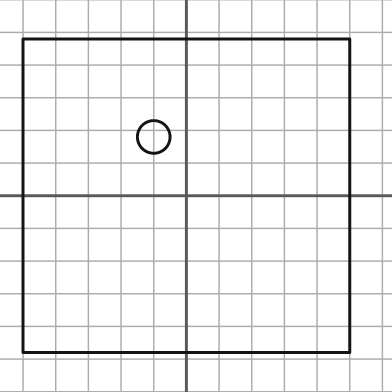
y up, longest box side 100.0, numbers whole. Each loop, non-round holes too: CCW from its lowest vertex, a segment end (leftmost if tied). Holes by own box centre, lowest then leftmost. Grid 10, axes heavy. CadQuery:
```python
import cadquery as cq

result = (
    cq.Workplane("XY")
    .moveTo(-50.0, -48.0)
    .lineTo(50.0, -48.0)
    .lineTo(50.0, 48.0)
    .lineTo(-50.0, 48.0)
    .close()
    .moveTo(-10.0, 18.0)
    .circle(5.0)
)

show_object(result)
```